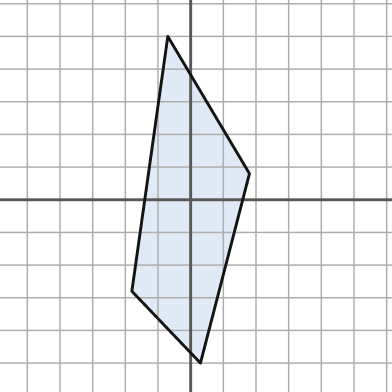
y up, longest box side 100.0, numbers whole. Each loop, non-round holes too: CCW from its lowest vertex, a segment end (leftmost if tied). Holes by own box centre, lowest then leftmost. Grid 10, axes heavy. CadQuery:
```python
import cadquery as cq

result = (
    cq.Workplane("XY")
    .moveTo(3.0, -50.0)
    .lineTo(18.0, 8.0)
    .lineTo(-7.0, 50.0)
    .lineTo(-18.0, -28.0)
    .close()
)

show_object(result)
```